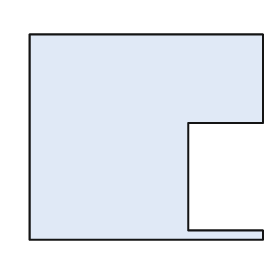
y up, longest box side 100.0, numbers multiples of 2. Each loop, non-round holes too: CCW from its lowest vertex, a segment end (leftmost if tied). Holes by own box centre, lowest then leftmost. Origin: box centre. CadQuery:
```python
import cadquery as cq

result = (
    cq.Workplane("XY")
    .moveTo(-50.0, -44.0)
    .lineTo(50.0, -44.0)
    .lineTo(50.0, -40.0)
    .lineTo(18.0, -40.0)
    .lineTo(18.0, 6.0)
    .lineTo(50.0, 6.0)
    .lineTo(50.0, 44.0)
    .lineTo(-50.0, 44.0)
    .close()
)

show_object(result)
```